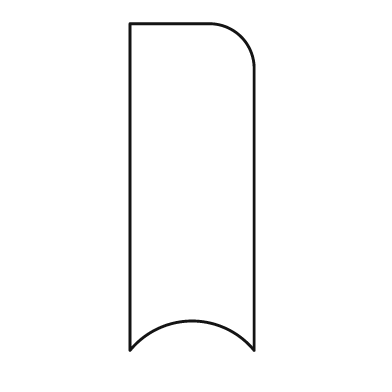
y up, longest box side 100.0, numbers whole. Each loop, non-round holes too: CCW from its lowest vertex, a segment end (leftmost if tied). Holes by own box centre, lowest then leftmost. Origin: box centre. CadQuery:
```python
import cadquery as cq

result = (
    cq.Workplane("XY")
    .moveTo(-19.0, -50.0)
    .threePointArc((0.0, -41.0), (19.0, -50.0))
    .lineTo(19.0, 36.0)
    .threePointArc((15.0, 46.0), (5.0, 50.0))
    .lineTo(-19.0, 50.0)
    .close()
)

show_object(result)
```